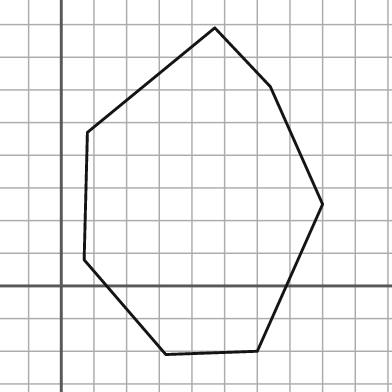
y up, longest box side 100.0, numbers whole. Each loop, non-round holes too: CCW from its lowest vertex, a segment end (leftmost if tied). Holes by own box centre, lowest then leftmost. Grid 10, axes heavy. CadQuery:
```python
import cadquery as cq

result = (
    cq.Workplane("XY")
    .moveTo(32.0, -21.0)
    .lineTo(60.0, -20.0)
    .lineTo(80.0, 25.0)
    .lineTo(64.0, 61.0)
    .lineTo(47.0, 79.0)
    .lineTo(8.0, 47.0)
    .lineTo(7.0, 8.0)
    .close()
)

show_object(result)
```